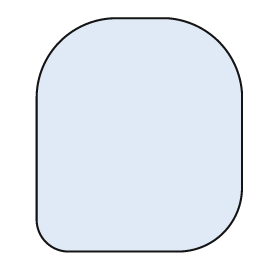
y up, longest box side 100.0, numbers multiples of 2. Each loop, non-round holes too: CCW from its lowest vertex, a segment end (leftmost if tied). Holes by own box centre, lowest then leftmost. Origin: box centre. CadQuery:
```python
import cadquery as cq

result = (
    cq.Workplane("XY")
    .moveTo(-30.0, -50.0)
    .lineTo(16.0, -50.0)
    .threePointArc((36.0, -42.0), (44.0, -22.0))
    .lineTo(44.0, 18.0)
    .threePointArc((34.0, 40.0), (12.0, 50.0))
    .lineTo(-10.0, 50.0)
    .threePointArc((-34.0, 40.0), (-44.0, 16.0))
    .lineTo(-44.0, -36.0)
    .threePointArc((-40.0, -46.0), (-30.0, -50.0))
    .close()
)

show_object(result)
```